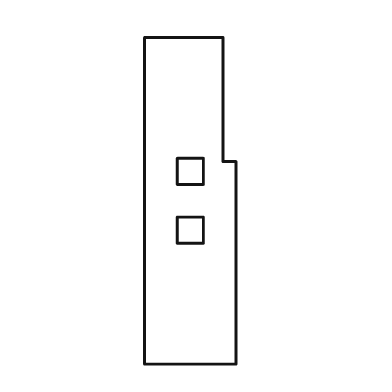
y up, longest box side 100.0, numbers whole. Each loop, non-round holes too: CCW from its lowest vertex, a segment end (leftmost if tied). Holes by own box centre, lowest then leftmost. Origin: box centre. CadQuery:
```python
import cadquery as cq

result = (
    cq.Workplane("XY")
    .moveTo(-14.0, -50.0)
    .lineTo(14.0, -50.0)
    .lineTo(14.0, 12.0)
    .lineTo(10.0, 12.0)
    .lineTo(10.0, 50.0)
    .lineTo(-14.0, 50.0)
    .close()
    .moveTo(-4.0, -13.0)
    .lineTo(4.0, -13.0)
    .lineTo(4.0, -5.0)
    .lineTo(-4.0, -5.0)
    .close()
    .moveTo(-4.0, 5.0)
    .lineTo(4.0, 5.0)
    .lineTo(4.0, 13.0)
    .lineTo(-4.0, 13.0)
    .close()
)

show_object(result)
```